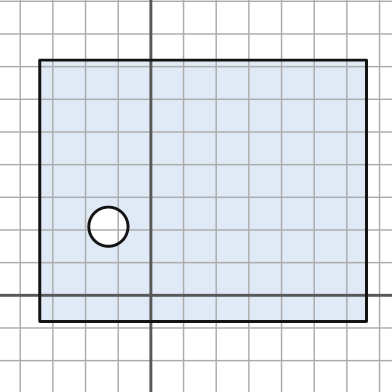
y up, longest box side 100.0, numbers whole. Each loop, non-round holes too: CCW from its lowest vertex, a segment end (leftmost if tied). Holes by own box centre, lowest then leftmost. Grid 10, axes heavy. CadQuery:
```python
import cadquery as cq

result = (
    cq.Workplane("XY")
    .moveTo(-34.0, -8.0)
    .lineTo(66.0, -8.0)
    .lineTo(66.0, 72.0)
    .lineTo(-34.0, 72.0)
    .close()
    .moveTo(-13.0, 21.0)
    .circle(6.0)
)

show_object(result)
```